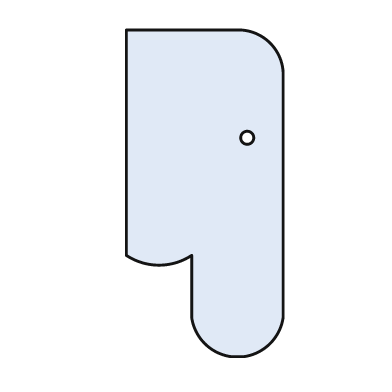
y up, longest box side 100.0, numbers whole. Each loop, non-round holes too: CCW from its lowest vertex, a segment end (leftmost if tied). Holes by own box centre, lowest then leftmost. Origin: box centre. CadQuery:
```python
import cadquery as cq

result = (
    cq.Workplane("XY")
    .moveTo(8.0, -50.0)
    .lineTo(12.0, -50.0)
    .threePointArc((20.0, -46.0), (24.0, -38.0))
    .lineTo(24.0, 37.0)
    .threePointArc((20.0, 46.0), (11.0, 50.0))
    .lineTo(-24.0, 50.0)
    .lineTo(-24.0, -19.0)
    .threePointArc((-14.0, -22.0), (-4.0, -19.0))
    .lineTo(-4.0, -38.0)
    .threePointArc((0.0, -46.0), (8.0, -50.0))
    .close()
    .moveTo(13.0, 17.0)
    .circle(2.0)
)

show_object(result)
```